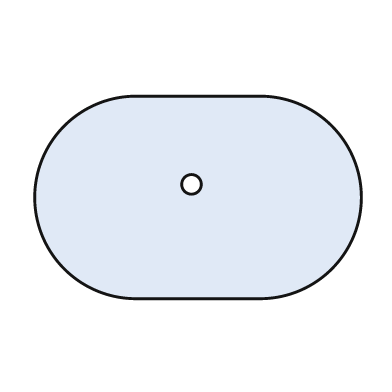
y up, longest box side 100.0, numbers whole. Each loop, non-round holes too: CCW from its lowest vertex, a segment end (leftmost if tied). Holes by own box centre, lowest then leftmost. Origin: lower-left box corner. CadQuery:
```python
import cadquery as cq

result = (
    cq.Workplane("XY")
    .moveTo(31.0, 0.0)
    .lineTo(69.0, 0.0)
    .threePointArc((100.0, 31.0), (69.0, 62.0))
    .lineTo(31.0, 62.0)
    .threePointArc((0.0, 31.0), (31.0, 0.0))
    .close()
    .moveTo(48.0, 35.0)
    .circle(3.0)
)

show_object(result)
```